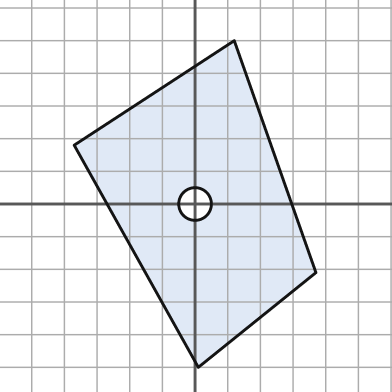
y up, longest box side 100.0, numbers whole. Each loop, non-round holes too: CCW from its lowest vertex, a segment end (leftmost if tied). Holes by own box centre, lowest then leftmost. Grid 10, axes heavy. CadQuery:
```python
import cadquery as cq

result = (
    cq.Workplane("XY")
    .moveTo(1.0, -50.0)
    .lineTo(37.0, -21.0)
    .lineTo(12.0, 50.0)
    .lineTo(-37.0, 18.0)
    .close()
    .moveTo(0.0, 0.0)
    .circle(5.0)
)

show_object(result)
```